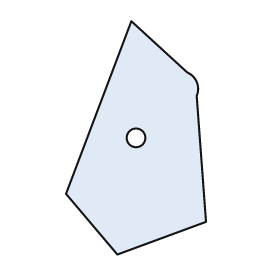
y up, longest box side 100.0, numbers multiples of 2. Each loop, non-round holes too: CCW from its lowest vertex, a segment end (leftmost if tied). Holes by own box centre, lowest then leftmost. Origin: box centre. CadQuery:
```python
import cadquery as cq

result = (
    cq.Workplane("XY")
    .moveTo(-8.0, -50.0)
    .lineTo(30.0, -36.0)
    .lineTo(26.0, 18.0)
    .threePointArc((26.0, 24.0), (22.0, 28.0))
    .lineTo(-2.0, 50.0)
    .lineTo(-30.0, -24.0)
    .close()
    .moveTo(0.0, 0.0)
    .circle(4.0)
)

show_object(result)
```